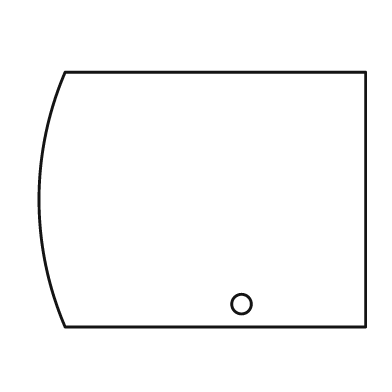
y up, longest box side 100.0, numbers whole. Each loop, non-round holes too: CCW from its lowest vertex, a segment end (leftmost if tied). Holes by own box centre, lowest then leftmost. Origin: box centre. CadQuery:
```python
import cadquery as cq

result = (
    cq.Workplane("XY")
    .moveTo(-42.0, -39.0)
    .lineTo(50.0, -39.0)
    .lineTo(50.0, 39.0)
    .lineTo(-42.0, 39.0)
    .threePointArc((-50.0, 0.0), (-42.0, -39.0))
    .close()
    .moveTo(12.0, -32.0)
    .circle(3.0)
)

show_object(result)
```